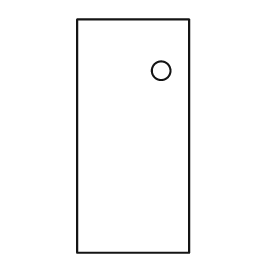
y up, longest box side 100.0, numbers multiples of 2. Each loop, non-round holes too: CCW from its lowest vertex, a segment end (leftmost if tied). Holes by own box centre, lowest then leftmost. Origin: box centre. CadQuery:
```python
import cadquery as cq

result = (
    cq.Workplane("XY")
    .moveTo(-24.0, -50.0)
    .lineTo(24.0, -50.0)
    .lineTo(24.0, 50.0)
    .lineTo(-24.0, 50.0)
    .close()
    .moveTo(12.0, 28.0)
    .circle(4.0)
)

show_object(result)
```